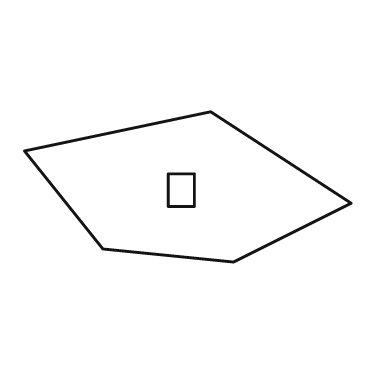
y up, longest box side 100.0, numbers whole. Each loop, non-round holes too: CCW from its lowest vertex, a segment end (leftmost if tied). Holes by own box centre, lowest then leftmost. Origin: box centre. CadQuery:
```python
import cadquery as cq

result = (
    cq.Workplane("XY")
    .moveTo(14.0, -23.0)
    .lineTo(50.0, -5.0)
    .lineTo(7.0, 23.0)
    .lineTo(-50.0, 11.0)
    .lineTo(-26.0, -19.0)
    .close()
    .moveTo(-6.0, -6.0)
    .lineTo(2.0, -6.0)
    .lineTo(2.0, 4.0)
    .lineTo(-6.0, 4.0)
    .close()
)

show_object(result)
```